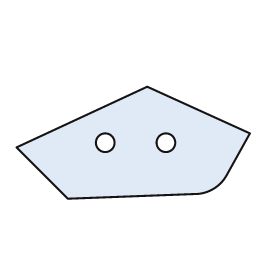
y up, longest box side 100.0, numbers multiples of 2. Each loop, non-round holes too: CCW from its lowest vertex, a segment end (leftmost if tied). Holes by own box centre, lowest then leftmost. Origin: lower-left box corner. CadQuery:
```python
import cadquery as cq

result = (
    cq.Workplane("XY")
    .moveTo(22.0, 0.0)
    .lineTo(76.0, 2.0)
    .threePointArc((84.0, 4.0), (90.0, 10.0))
    .lineTo(100.0, 28.0)
    .lineTo(56.0, 48.0)
    .lineTo(0.0, 22.0)
    .close()
    .moveTo(38.0, 24.0)
    .circle(4.0)
    .moveTo(64.0, 24.0)
    .circle(4.0)
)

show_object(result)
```